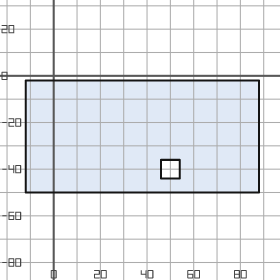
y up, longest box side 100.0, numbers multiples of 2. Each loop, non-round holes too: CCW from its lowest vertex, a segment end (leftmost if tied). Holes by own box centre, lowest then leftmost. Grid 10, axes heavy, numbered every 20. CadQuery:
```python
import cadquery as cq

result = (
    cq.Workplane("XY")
    .moveTo(-12.0, -50.0)
    .lineTo(88.0, -50.0)
    .lineTo(88.0, -2.0)
    .lineTo(-12.0, -2.0)
    .close()
    .moveTo(46.0, -44.0)
    .lineTo(54.0, -44.0)
    .lineTo(54.0, -36.0)
    .lineTo(46.0, -36.0)
    .close()
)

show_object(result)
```